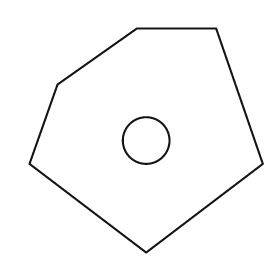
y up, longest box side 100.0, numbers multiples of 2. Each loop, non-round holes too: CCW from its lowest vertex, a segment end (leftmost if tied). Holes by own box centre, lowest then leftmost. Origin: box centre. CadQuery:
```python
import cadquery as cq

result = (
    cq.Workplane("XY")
    .moveTo(0.0, -48.0)
    .lineTo(50.0, -10.0)
    .lineTo(30.0, 48.0)
    .lineTo(-4.0, 48.0)
    .lineTo(-38.0, 24.0)
    .lineTo(-50.0, -10.0)
    .close()
    .moveTo(0.0, 0.0)
    .circle(10.0)
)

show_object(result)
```